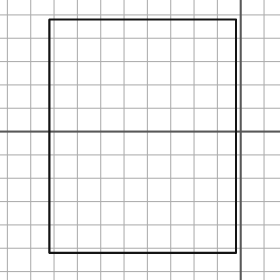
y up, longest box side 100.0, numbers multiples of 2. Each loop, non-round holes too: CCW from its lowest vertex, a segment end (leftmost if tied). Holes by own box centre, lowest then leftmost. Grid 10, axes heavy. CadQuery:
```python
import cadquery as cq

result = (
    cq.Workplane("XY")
    .moveTo(-82.0, -52.0)
    .lineTo(-2.0, -52.0)
    .lineTo(-2.0, 48.0)
    .lineTo(-82.0, 48.0)
    .close()
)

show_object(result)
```